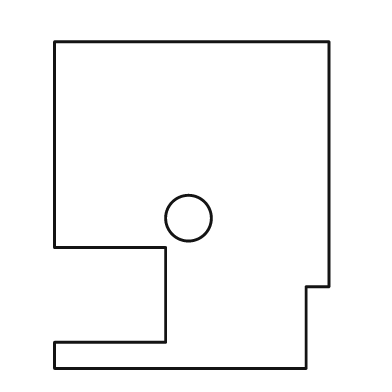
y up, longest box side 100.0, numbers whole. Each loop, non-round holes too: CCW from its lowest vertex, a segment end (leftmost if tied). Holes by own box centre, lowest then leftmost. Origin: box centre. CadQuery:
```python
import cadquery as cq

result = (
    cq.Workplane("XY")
    .moveTo(-42.0, -50.0)
    .lineTo(35.0, -50.0)
    .lineTo(35.0, -25.0)
    .lineTo(42.0, -25.0)
    .lineTo(42.0, 50.0)
    .lineTo(-42.0, 50.0)
    .lineTo(-42.0, -13.0)
    .lineTo(-8.0, -13.0)
    .lineTo(-8.0, -42.0)
    .lineTo(-42.0, -42.0)
    .close()
    .moveTo(-1.0, -4.0)
    .circle(7.0)
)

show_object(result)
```